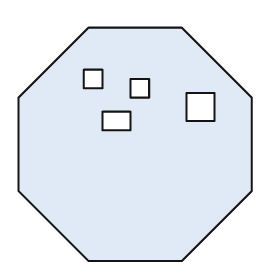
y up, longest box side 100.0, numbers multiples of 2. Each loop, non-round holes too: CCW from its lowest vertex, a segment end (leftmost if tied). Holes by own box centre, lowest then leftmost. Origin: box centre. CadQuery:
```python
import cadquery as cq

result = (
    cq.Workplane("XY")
    .moveTo(-20.0, -50.0)
    .lineTo(20.0, -50.0)
    .lineTo(50.0, -20.0)
    .lineTo(50.0, 20.0)
    .lineTo(20.0, 50.0)
    .lineTo(-20.0, 50.0)
    .lineTo(-50.0, 20.0)
    .lineTo(-50.0, -20.0)
    .close()
    .moveTo(-14.0, 6.0)
    .lineTo(-2.0, 6.0)
    .lineTo(-2.0, 14.0)
    .lineTo(-14.0, 14.0)
    .close()
    .moveTo(22.0, 10.0)
    .lineTo(34.0, 10.0)
    .lineTo(34.0, 22.0)
    .lineTo(22.0, 22.0)
    .close()
    .moveTo(-2.0, 20.0)
    .lineTo(6.0, 20.0)
    .lineTo(6.0, 28.0)
    .lineTo(-2.0, 28.0)
    .close()
    .moveTo(-22.0, 24.0)
    .lineTo(-14.0, 24.0)
    .lineTo(-14.0, 32.0)
    .lineTo(-22.0, 32.0)
    .close()
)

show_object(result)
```